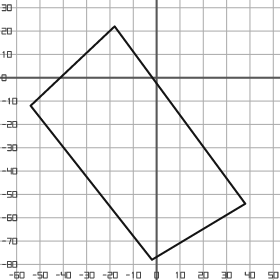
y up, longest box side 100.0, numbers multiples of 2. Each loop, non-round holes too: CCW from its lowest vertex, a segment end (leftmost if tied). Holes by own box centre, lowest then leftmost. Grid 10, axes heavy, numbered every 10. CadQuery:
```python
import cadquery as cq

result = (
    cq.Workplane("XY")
    .moveTo(-2.0, -78.0)
    .lineTo(38.0, -54.0)
    .lineTo(-18.0, 22.0)
    .lineTo(-54.0, -12.0)
    .close()
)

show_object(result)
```